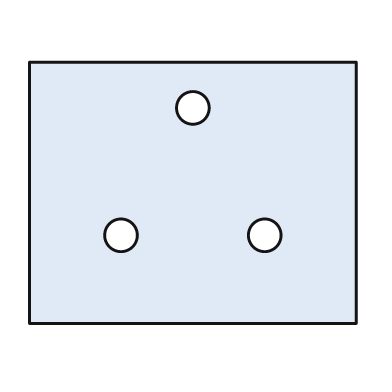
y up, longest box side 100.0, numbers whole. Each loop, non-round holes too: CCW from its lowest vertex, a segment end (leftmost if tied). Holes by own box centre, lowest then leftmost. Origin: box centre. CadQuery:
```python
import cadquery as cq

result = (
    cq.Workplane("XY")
    .moveTo(-50.0, -40.0)
    .lineTo(50.0, -40.0)
    .lineTo(50.0, 40.0)
    .lineTo(-50.0, 40.0)
    .close()
    .moveTo(-22.0, -13.0)
    .circle(5.0)
    .moveTo(22.0, -13.0)
    .circle(5.0)
    .moveTo(0.0, 26.0)
    .circle(5.0)
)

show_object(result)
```